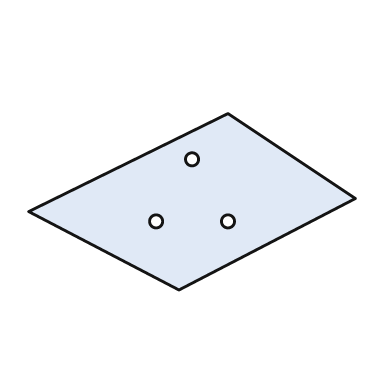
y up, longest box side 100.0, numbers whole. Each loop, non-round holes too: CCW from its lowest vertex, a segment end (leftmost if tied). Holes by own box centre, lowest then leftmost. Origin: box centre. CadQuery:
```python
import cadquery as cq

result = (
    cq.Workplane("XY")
    .moveTo(-4.0, -27.0)
    .lineTo(50.0, 1.0)
    .lineTo(11.0, 27.0)
    .lineTo(-50.0, -3.0)
    .close()
    .moveTo(-11.0, -6.0)
    .circle(2.0)
    .moveTo(11.0, -6.0)
    .circle(2.0)
    .moveTo(0.0, 13.0)
    .circle(2.0)
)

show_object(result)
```